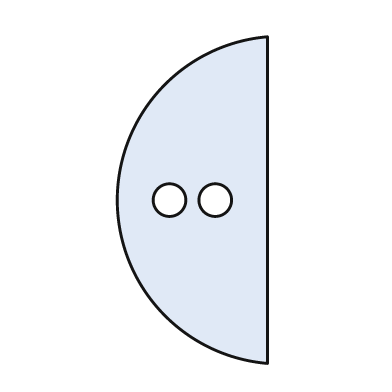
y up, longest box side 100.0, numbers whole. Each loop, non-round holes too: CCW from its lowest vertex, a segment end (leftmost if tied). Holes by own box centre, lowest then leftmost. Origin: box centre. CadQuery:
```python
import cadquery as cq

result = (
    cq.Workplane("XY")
    .moveTo(23.0, -50.0)
    .lineTo(23.0, 50.0)
    .threePointArc((-23.0, 0.0), (23.0, -50.0))
    .close()
    .moveTo(-7.0, 0.0)
    .circle(5.0)
    .moveTo(7.0, 0.0)
    .circle(5.0)
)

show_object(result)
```